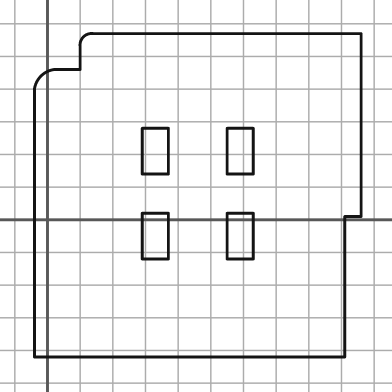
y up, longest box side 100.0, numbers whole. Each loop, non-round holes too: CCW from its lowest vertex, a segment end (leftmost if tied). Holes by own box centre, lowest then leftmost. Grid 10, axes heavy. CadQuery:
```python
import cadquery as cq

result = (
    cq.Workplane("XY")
    .moveTo(-4.0, -42.0)
    .lineTo(91.0, -42.0)
    .lineTo(91.0, 1.0)
    .lineTo(96.0, 1.0)
    .lineTo(96.0, 57.0)
    .lineTo(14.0, 57.0)
    .threePointArc((11.0, 56.0), (10.0, 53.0))
    .lineTo(10.0, 46.0)
    .lineTo(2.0, 46.0)
    .threePointArc((-2.0, 44.0), (-4.0, 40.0))
    .close()
    .moveTo(29.0, -12.0)
    .lineTo(37.0, -12.0)
    .lineTo(37.0, 2.0)
    .lineTo(29.0, 2.0)
    .close()
    .moveTo(55.0, -12.0)
    .lineTo(63.0, -12.0)
    .lineTo(63.0, 2.0)
    .lineTo(55.0, 2.0)
    .close()
    .moveTo(29.0, 14.0)
    .lineTo(37.0, 14.0)
    .lineTo(37.0, 28.0)
    .lineTo(29.0, 28.0)
    .close()
    .moveTo(55.0, 14.0)
    .lineTo(63.0, 14.0)
    .lineTo(63.0, 28.0)
    .lineTo(55.0, 28.0)
    .close()
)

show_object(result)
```